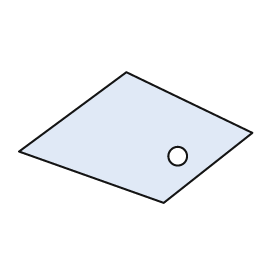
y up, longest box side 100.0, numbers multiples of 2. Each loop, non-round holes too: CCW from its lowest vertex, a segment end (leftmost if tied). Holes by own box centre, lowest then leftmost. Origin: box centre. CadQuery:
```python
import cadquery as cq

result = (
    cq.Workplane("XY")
    .moveTo(12.0, -28.0)
    .lineTo(50.0, 2.0)
    .lineTo(-4.0, 28.0)
    .lineTo(-50.0, -6.0)
    .close()
    .moveTo(18.0, -8.0)
    .circle(4.0)
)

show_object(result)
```